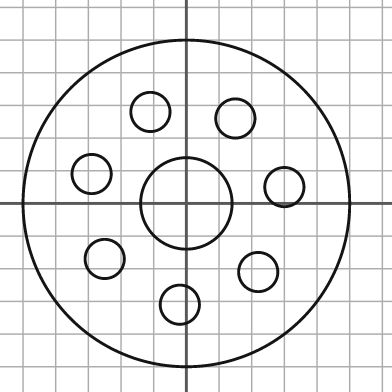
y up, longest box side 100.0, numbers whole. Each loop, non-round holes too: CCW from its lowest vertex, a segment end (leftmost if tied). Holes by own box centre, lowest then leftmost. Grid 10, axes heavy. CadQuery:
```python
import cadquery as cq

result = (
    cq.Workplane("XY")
    .moveTo(0.0, 0.0)
    .circle(50.0)
    .moveTo(-2.0, -31.0)
    .circle(6.0)
    .moveTo(22.0, -21.0)
    .circle(6.0)
    .moveTo(-25.0, -17.0)
    .circle(6.0)
    .moveTo(0.0, 0.0)
    .circle(14.0)
    .moveTo(30.0, 5.0)
    .circle(6.0)
    .moveTo(-29.0, 9.0)
    .circle(6.0)
    .moveTo(15.0, 26.0)
    .circle(6.0)
    .moveTo(-11.0, 28.0)
    .circle(6.0)
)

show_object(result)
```